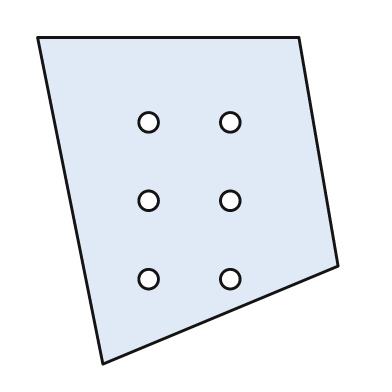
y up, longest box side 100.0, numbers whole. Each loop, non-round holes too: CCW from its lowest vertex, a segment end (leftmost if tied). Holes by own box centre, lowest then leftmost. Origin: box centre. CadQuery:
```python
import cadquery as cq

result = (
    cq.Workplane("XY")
    .moveTo(-26.0, -50.0)
    .lineTo(46.0, -20.0)
    .lineTo(34.0, 50.0)
    .lineTo(-46.0, 50.0)
    .close()
    .moveTo(-12.0, -24.0)
    .circle(3.0)
    .moveTo(13.0, -24.0)
    .circle(3.0)
    .moveTo(-12.0, 0.0)
    .circle(3.0)
    .moveTo(13.0, 0.0)
    .circle(3.0)
    .moveTo(-12.0, 24.0)
    .circle(3.0)
    .moveTo(13.0, 24.0)
    .circle(3.0)
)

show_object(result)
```